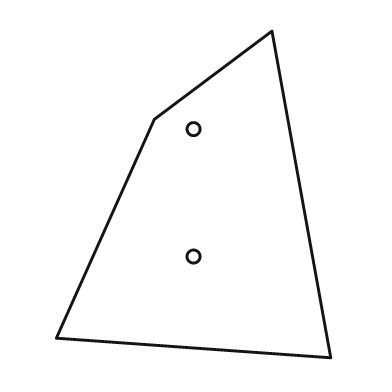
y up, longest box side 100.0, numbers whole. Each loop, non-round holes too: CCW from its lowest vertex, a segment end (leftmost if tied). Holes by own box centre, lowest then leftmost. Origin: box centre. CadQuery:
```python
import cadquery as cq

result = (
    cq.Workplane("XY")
    .moveTo(42.0, -50.0)
    .lineTo(24.0, 50.0)
    .lineTo(-12.0, 23.0)
    .lineTo(-42.0, -44.0)
    .close()
    .moveTo(0.0, -19.0)
    .circle(2.0)
    .moveTo(0.0, 20.0)
    .circle(2.0)
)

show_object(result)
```